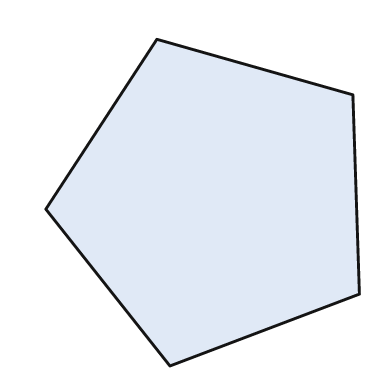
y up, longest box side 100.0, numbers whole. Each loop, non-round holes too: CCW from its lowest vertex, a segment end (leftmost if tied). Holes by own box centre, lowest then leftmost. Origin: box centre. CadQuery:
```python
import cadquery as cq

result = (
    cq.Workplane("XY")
    .moveTo(-10.0, -50.0)
    .lineTo(48.0, -28.0)
    .lineTo(46.0, 33.0)
    .lineTo(-14.0, 50.0)
    .lineTo(-48.0, -2.0)
    .close()
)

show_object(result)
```